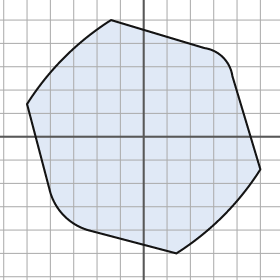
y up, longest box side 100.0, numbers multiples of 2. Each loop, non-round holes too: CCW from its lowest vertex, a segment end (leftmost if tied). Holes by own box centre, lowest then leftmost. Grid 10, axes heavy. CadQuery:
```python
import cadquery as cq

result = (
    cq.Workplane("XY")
    .moveTo(14.0, -50.0)
    .threePointArc((34.0, -34.0), (50.0, -14.0))
    .lineTo(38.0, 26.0)
    .threePointArc((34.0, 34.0), (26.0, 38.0))
    .lineTo(-14.0, 50.0)
    .threePointArc((-34.0, 34.0), (-50.0, 14.0))
    .lineTo(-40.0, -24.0)
    .threePointArc((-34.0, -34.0), (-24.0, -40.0))
    .close()
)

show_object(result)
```